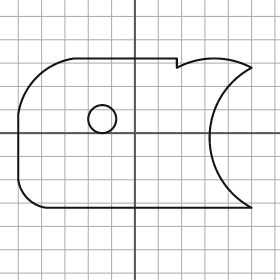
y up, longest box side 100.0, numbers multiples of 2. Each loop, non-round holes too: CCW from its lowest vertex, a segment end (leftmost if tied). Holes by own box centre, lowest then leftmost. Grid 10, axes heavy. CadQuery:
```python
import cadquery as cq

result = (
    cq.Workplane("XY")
    .moveTo(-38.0, -32.0)
    .lineTo(50.0, -32.0)
    .threePointArc((32.0, -2.0), (50.0, 28.0))
    .threePointArc((34.0, 32.0), (18.0, 28.0))
    .lineTo(18.0, 32.0)
    .lineTo(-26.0, 32.0)
    .threePointArc((-42.0, 24.0), (-50.0, 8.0))
    .lineTo(-50.0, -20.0)
    .threePointArc((-46.0, -28.0), (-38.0, -32.0))
    .close()
    .moveTo(-14.0, 6.0)
    .circle(6.0)
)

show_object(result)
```